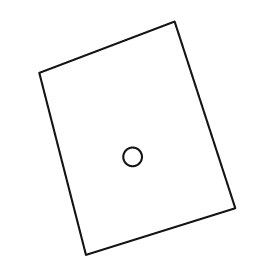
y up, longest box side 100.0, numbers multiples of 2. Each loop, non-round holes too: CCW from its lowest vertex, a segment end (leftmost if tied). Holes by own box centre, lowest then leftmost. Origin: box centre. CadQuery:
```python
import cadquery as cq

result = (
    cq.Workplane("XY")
    .moveTo(-22.0, -50.0)
    .lineTo(42.0, -30.0)
    .lineTo(16.0, 50.0)
    .lineTo(-42.0, 28.0)
    .close()
    .moveTo(-2.0, -8.0)
    .circle(4.0)
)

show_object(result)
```